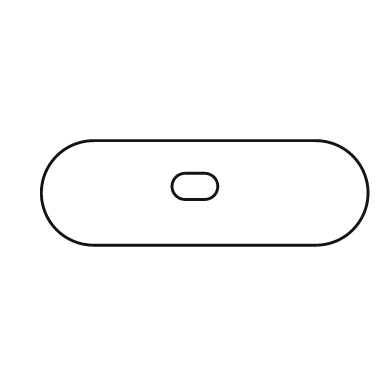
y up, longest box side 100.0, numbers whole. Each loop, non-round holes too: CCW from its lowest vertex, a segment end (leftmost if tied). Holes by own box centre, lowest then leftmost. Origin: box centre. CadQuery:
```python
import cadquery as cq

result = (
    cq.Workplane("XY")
    .moveTo(-34.0, -16.0)
    .lineTo(34.0, -16.0)
    .threePointArc((50.0, 0.0), (34.0, 16.0))
    .lineTo(-34.0, 16.0)
    .threePointArc((-50.0, 0.0), (-34.0, -16.0))
    .close()
    .moveTo(-6.0, -2.0)
    .lineTo(0.0, -2.0)
    .threePointArc((4.0, 2.0), (0.0, 6.0))
    .lineTo(-6.0, 6.0)
    .threePointArc((-10.0, 2.0), (-6.0, -2.0))
    .close()
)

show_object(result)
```